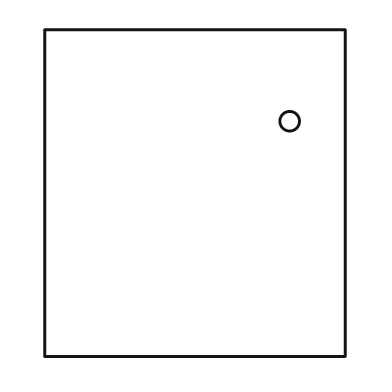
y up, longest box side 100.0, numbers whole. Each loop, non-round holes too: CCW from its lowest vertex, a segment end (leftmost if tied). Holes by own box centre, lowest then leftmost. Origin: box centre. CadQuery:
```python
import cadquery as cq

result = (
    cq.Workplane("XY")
    .moveTo(-46.0, -50.0)
    .lineTo(46.0, -50.0)
    .lineTo(46.0, 50.0)
    .lineTo(-46.0, 50.0)
    .close()
    .moveTo(29.0, 22.0)
    .circle(3.0)
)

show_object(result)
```